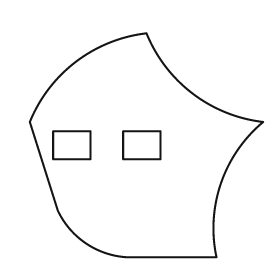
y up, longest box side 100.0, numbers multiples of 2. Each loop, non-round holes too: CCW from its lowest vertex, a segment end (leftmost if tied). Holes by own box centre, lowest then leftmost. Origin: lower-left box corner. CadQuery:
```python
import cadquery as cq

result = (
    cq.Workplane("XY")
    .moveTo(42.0, 0.0)
    .lineTo(80.0, 0.0)
    .threePointArc((82.0, 32.0), (100.0, 58.0))
    .threePointArc((70.0, 70.0), (50.0, 96.0))
    .threePointArc((20.0, 84.0), (0.0, 58.0))
    .lineTo(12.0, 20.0)
    .threePointArc((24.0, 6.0), (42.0, 0.0))
    .close()
    .moveTo(10.0, 42.0)
    .lineTo(26.0, 42.0)
    .lineTo(26.0, 54.0)
    .lineTo(10.0, 54.0)
    .close()
    .moveTo(40.0, 42.0)
    .lineTo(56.0, 42.0)
    .lineTo(56.0, 54.0)
    .lineTo(40.0, 54.0)
    .close()
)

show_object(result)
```